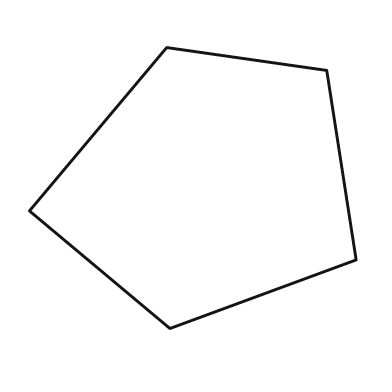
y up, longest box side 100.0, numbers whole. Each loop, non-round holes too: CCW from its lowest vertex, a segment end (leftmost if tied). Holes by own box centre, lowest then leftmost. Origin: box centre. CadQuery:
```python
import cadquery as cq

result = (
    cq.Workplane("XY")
    .moveTo(-7.0, -43.0)
    .lineTo(50.0, -22.0)
    .lineTo(41.0, 36.0)
    .lineTo(-8.0, 43.0)
    .lineTo(-50.0, -7.0)
    .close()
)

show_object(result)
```